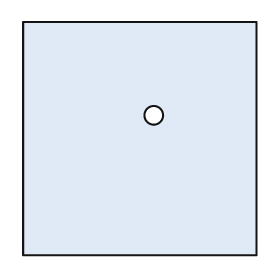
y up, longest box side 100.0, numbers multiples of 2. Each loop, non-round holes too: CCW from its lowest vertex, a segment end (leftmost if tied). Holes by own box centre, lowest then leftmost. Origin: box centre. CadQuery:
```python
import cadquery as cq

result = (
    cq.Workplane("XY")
    .moveTo(-50.0, -50.0)
    .lineTo(50.0, -50.0)
    .lineTo(50.0, 50.0)
    .lineTo(-50.0, 50.0)
    .close()
    .moveTo(6.0, 10.0)
    .circle(4.0)
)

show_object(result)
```